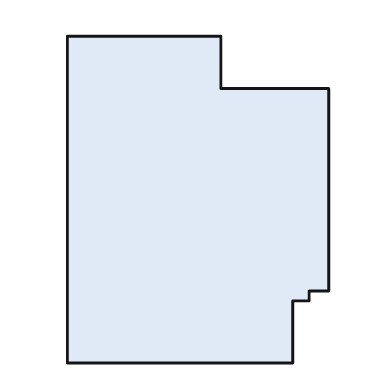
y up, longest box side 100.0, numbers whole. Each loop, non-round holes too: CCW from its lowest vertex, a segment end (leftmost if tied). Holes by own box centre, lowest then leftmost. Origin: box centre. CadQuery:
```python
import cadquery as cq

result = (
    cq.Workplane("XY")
    .moveTo(-40.0, -50.0)
    .lineTo(29.0, -50.0)
    .lineTo(29.0, -31.0)
    .lineTo(34.0, -31.0)
    .lineTo(34.0, -28.0)
    .lineTo(40.0, -28.0)
    .lineTo(40.0, 34.0)
    .lineTo(7.0, 34.0)
    .lineTo(7.0, 50.0)
    .lineTo(-40.0, 50.0)
    .close()
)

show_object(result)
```